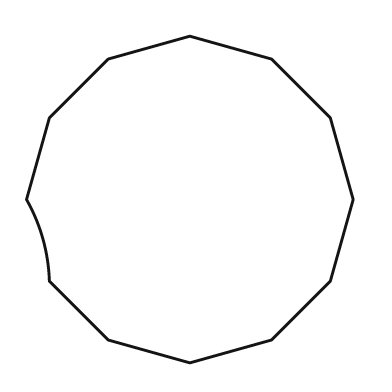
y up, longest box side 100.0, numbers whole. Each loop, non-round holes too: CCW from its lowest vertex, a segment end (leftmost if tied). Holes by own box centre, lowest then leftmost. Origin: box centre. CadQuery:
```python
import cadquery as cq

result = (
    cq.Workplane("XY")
    .moveTo(0.0, -50.0)
    .lineTo(25.0, -43.0)
    .lineTo(43.0, -25.0)
    .lineTo(50.0, 0.0)
    .lineTo(43.0, 25.0)
    .lineTo(25.0, 43.0)
    .lineTo(0.0, 50.0)
    .lineTo(-25.0, 43.0)
    .lineTo(-43.0, 25.0)
    .lineTo(-50.0, 0.0)
    .threePointArc((-45.0, -12.0), (-43.0, -25.0))
    .lineTo(-25.0, -43.0)
    .close()
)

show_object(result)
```